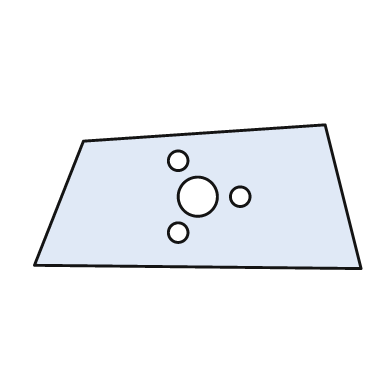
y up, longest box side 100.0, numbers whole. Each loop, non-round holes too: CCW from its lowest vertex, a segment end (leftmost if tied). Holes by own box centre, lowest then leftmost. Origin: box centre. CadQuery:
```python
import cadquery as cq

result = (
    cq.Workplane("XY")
    .moveTo(50.0, -22.0)
    .lineTo(39.0, 22.0)
    .lineTo(-35.0, 17.0)
    .lineTo(-50.0, -21.0)
    .close()
    .moveTo(-6.0, -11.0)
    .circle(3.0)
    .moveTo(0.0, 0.0)
    .circle(6.0)
    .moveTo(13.0, 0.0)
    .circle(3.0)
    .moveTo(-6.0, 11.0)
    .circle(3.0)
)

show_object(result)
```